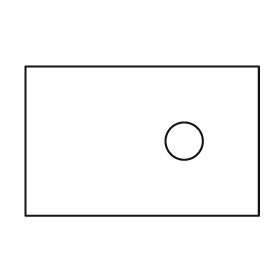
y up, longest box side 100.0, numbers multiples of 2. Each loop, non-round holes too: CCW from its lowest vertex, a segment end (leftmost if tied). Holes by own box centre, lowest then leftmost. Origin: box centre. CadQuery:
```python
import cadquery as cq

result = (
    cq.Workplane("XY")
    .moveTo(-50.0, -32.0)
    .lineTo(50.0, -32.0)
    .lineTo(50.0, 32.0)
    .lineTo(-50.0, 32.0)
    .close()
    .moveTo(18.0, 0.0)
    .circle(8.0)
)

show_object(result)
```